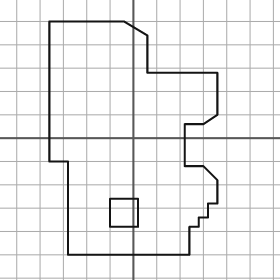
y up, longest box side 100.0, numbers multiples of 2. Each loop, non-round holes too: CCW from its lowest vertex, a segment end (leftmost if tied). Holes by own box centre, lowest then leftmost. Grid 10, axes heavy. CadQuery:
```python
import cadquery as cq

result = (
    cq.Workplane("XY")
    .moveTo(-28.0, -50.0)
    .lineTo(24.0, -50.0)
    .lineTo(24.0, -38.0)
    .lineTo(28.0, -38.0)
    .lineTo(28.0, -34.0)
    .lineTo(32.0, -34.0)
    .lineTo(32.0, -28.0)
    .lineTo(36.0, -28.0)
    .lineTo(36.0, -18.0)
    .lineTo(30.0, -12.0)
    .lineTo(22.0, -12.0)
    .lineTo(22.0, 6.0)
    .lineTo(30.0, 6.0)
    .lineTo(36.0, 10.0)
    .lineTo(36.0, 28.0)
    .lineTo(6.0, 28.0)
    .lineTo(6.0, 44.0)
    .lineTo(-4.0, 50.0)
    .lineTo(-36.0, 50.0)
    .lineTo(-36.0, -10.0)
    .lineTo(-28.0, -10.0)
    .close()
    .moveTo(-10.0, -38.0)
    .lineTo(2.0, -38.0)
    .lineTo(2.0, -26.0)
    .lineTo(-10.0, -26.0)
    .close()
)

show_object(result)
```